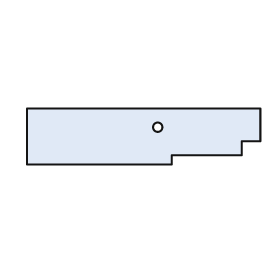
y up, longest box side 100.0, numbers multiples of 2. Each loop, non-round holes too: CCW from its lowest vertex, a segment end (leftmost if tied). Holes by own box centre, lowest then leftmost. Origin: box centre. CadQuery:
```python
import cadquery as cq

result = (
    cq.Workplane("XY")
    .moveTo(-50.0, -12.0)
    .lineTo(12.0, -12.0)
    .lineTo(12.0, -8.0)
    .lineTo(42.0, -8.0)
    .lineTo(42.0, -2.0)
    .lineTo(50.0, -2.0)
    .lineTo(50.0, 12.0)
    .lineTo(-50.0, 12.0)
    .close()
    .moveTo(6.0, 4.0)
    .circle(2.0)
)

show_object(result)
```